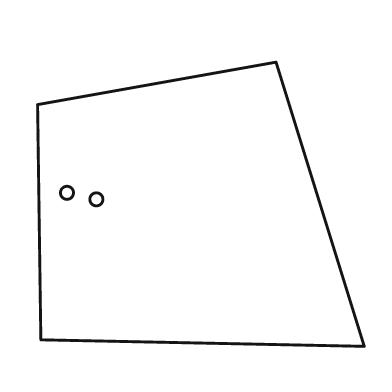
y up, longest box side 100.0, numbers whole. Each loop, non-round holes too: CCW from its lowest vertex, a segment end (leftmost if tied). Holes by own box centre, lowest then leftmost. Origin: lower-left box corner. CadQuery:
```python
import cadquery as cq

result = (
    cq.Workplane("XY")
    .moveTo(100.0, 0.0)
    .lineTo(73.0, 87.0)
    .lineTo(0.0, 74.0)
    .lineTo(1.0, 2.0)
    .close()
    .moveTo(18.0, 45.0)
    .circle(2.0)
    .moveTo(9.0, 47.0)
    .circle(2.0)
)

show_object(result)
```